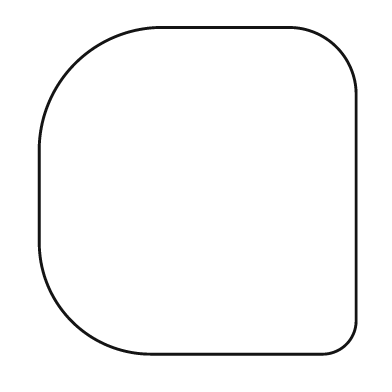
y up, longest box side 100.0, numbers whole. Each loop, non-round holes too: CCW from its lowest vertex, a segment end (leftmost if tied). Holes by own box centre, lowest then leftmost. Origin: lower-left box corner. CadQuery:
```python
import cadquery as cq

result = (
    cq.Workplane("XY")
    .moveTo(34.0, 0.0)
    .lineTo(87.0, 0.0)
    .threePointArc((94.0, 3.0), (97.0, 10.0))
    .lineTo(97.0, 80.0)
    .threePointArc((91.0, 94.0), (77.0, 100.0))
    .lineTo(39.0, 100.0)
    .threePointArc((11.0, 89.0), (0.0, 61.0))
    .lineTo(0.0, 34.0)
    .threePointArc((10.0, 10.0), (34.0, 0.0))
    .close()
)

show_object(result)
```